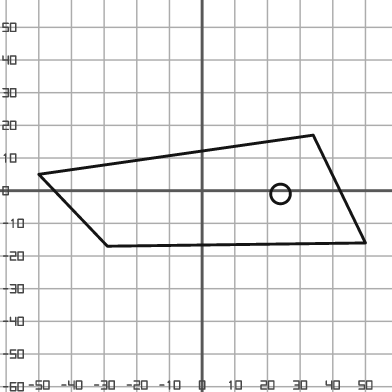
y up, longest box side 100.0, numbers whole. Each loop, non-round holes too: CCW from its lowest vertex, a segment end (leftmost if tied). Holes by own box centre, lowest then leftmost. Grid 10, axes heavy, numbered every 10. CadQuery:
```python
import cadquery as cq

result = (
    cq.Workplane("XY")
    .moveTo(-29.0, -17.0)
    .lineTo(50.0, -16.0)
    .lineTo(34.0, 17.0)
    .lineTo(-50.0, 5.0)
    .close()
    .moveTo(24.0, -1.0)
    .circle(3.0)
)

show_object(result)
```